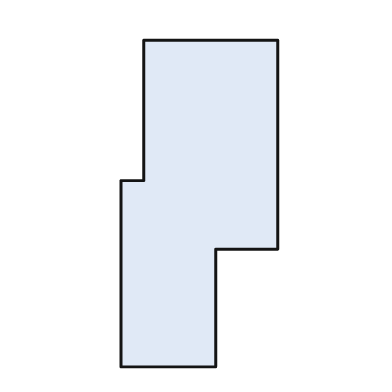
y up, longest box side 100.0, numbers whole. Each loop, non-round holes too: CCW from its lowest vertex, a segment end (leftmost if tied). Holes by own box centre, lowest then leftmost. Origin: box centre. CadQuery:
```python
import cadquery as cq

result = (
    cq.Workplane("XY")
    .moveTo(-24.0, -50.0)
    .lineTo(5.0, -50.0)
    .lineTo(5.0, -14.0)
    .lineTo(24.0, -14.0)
    .lineTo(24.0, 50.0)
    .lineTo(-17.0, 50.0)
    .lineTo(-17.0, 7.0)
    .lineTo(-24.0, 7.0)
    .close()
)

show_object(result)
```